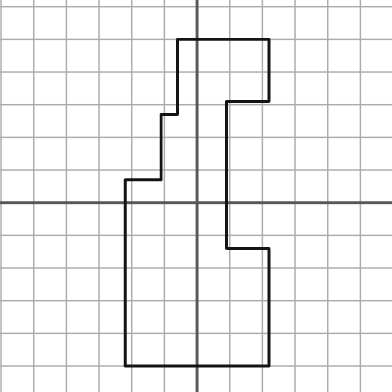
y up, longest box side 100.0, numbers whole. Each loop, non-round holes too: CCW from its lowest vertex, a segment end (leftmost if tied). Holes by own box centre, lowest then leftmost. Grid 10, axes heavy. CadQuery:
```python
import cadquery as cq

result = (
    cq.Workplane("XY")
    .moveTo(-22.0, -50.0)
    .lineTo(22.0, -50.0)
    .lineTo(22.0, -14.0)
    .lineTo(9.0, -14.0)
    .lineTo(9.0, 31.0)
    .lineTo(22.0, 31.0)
    .lineTo(22.0, 50.0)
    .lineTo(-6.0, 50.0)
    .lineTo(-6.0, 27.0)
    .lineTo(-11.0, 27.0)
    .lineTo(-11.0, 7.0)
    .lineTo(-22.0, 7.0)
    .close()
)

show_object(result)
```